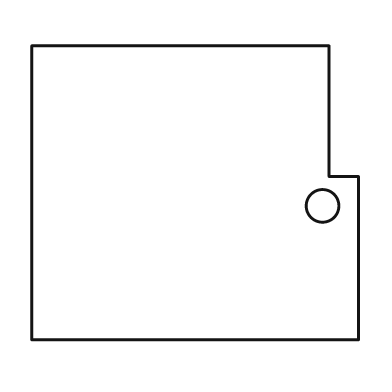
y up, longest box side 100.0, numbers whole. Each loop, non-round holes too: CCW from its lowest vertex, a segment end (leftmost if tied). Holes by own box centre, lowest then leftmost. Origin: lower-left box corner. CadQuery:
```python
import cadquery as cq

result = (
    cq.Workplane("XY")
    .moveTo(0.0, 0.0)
    .lineTo(100.0, 0.0)
    .lineTo(100.0, 50.0)
    .lineTo(91.0, 50.0)
    .lineTo(91.0, 90.0)
    .lineTo(0.0, 90.0)
    .close()
    .moveTo(89.0, 41.0)
    .circle(5.0)
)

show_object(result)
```